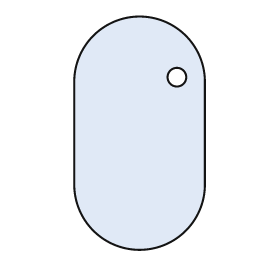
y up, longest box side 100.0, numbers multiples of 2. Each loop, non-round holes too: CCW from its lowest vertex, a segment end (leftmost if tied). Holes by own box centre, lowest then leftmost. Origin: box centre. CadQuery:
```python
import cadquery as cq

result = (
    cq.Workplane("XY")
    .moveTo(-28.0, -22.0)
    .threePointArc((0.0, -50.0), (28.0, -22.0))
    .lineTo(28.0, 22.0)
    .threePointArc((0.0, 50.0), (-28.0, 22.0))
    .close()
    .moveTo(16.0, 24.0)
    .circle(4.0)
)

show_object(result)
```